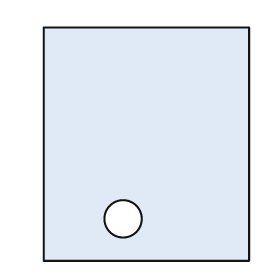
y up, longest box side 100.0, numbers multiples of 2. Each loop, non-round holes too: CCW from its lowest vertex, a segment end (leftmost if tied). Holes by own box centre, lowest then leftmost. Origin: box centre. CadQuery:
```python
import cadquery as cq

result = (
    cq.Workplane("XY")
    .moveTo(-44.0, -50.0)
    .lineTo(44.0, -50.0)
    .lineTo(44.0, 50.0)
    .lineTo(-44.0, 50.0)
    .close()
    .moveTo(-10.0, -32.0)
    .circle(8.0)
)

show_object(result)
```